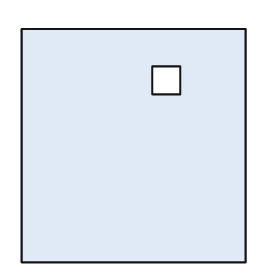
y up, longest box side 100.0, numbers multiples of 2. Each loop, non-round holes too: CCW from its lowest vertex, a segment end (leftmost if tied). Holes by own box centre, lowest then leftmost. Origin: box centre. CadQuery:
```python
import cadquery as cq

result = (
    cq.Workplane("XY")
    .moveTo(-48.0, -50.0)
    .lineTo(48.0, -50.0)
    .lineTo(48.0, 50.0)
    .lineTo(-48.0, 50.0)
    .close()
    .moveTo(8.0, 22.0)
    .lineTo(20.0, 22.0)
    .lineTo(20.0, 34.0)
    .lineTo(8.0, 34.0)
    .close()
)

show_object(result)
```